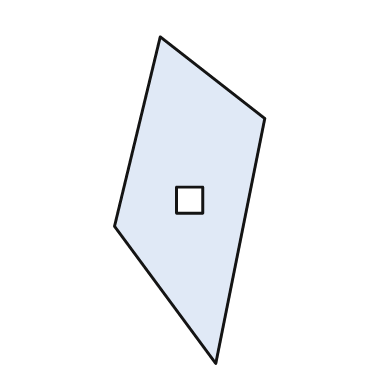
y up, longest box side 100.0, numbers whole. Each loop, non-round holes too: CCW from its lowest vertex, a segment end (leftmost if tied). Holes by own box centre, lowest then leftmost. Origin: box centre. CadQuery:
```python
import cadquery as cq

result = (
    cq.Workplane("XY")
    .moveTo(8.0, -50.0)
    .lineTo(23.0, 25.0)
    .lineTo(-9.0, 50.0)
    .lineTo(-23.0, -8.0)
    .close()
    .moveTo(-4.0, -4.0)
    .lineTo(4.0, -4.0)
    .lineTo(4.0, 4.0)
    .lineTo(-4.0, 4.0)
    .close()
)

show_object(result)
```